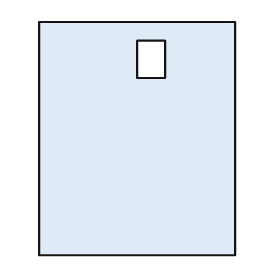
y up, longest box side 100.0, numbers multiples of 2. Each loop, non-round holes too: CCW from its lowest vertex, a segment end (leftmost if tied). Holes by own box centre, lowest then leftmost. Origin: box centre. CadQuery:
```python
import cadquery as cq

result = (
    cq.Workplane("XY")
    .moveTo(-42.0, -50.0)
    .lineTo(42.0, -50.0)
    .lineTo(42.0, 50.0)
    .lineTo(-42.0, 50.0)
    .close()
    .moveTo(0.0, 26.0)
    .lineTo(12.0, 26.0)
    .lineTo(12.0, 42.0)
    .lineTo(0.0, 42.0)
    .close()
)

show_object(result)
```